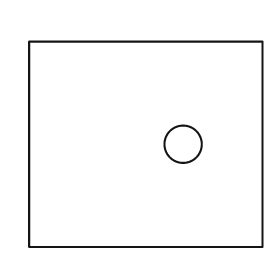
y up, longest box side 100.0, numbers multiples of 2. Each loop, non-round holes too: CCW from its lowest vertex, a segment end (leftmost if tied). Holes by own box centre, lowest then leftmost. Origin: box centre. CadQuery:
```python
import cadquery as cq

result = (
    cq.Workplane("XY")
    .moveTo(-50.0, -44.0)
    .lineTo(50.0, -44.0)
    .lineTo(50.0, 44.0)
    .lineTo(-50.0, 44.0)
    .close()
    .moveTo(16.0, 0.0)
    .circle(8.0)
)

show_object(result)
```